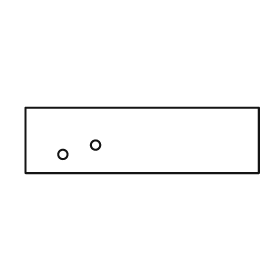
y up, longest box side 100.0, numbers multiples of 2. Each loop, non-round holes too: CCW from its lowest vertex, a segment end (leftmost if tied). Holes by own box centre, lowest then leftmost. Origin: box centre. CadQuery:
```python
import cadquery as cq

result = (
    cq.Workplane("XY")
    .moveTo(-50.0, -14.0)
    .lineTo(50.0, -14.0)
    .lineTo(50.0, 14.0)
    .lineTo(-50.0, 14.0)
    .close()
    .moveTo(-34.0, -6.0)
    .circle(2.0)
    .moveTo(-20.0, -2.0)
    .circle(2.0)
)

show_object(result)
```